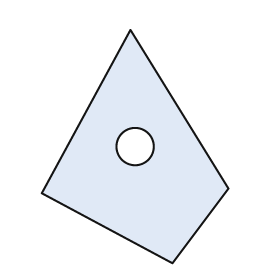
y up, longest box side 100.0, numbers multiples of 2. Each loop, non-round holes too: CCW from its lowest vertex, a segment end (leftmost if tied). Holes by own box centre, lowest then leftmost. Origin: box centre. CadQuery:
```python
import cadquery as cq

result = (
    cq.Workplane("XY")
    .moveTo(16.0, -50.0)
    .lineTo(40.0, -18.0)
    .lineTo(-2.0, 50.0)
    .lineTo(-40.0, -20.0)
    .close()
    .moveTo(0.0, 0.0)
    .circle(8.0)
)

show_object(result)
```